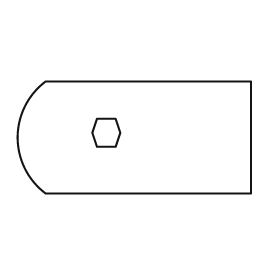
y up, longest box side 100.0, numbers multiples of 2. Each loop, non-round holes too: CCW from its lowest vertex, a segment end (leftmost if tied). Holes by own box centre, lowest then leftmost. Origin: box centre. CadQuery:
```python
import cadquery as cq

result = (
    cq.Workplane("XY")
    .moveTo(-38.0, -24.0)
    .lineTo(50.0, -24.0)
    .lineTo(50.0, 24.0)
    .lineTo(-38.0, 24.0)
    .threePointArc((-50.0, 0.0), (-38.0, -24.0))
    .close()
    .moveTo(-16.0, -4.0)
    .lineTo(-8.0, -4.0)
    .lineTo(-6.0, 2.0)
    .lineTo(-8.0, 8.0)
    .lineTo(-16.0, 8.0)
    .lineTo(-18.0, 2.0)
    .close()
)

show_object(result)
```